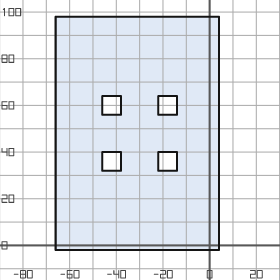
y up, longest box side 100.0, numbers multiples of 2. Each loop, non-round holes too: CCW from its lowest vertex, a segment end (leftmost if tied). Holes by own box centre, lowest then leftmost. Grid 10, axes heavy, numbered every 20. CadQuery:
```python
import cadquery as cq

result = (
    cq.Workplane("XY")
    .moveTo(-66.0, -2.0)
    .lineTo(4.0, -2.0)
    .lineTo(4.0, 98.0)
    .lineTo(-66.0, 98.0)
    .close()
    .moveTo(-46.0, 32.0)
    .lineTo(-38.0, 32.0)
    .lineTo(-38.0, 40.0)
    .lineTo(-46.0, 40.0)
    .close()
    .moveTo(-22.0, 32.0)
    .lineTo(-14.0, 32.0)
    .lineTo(-14.0, 40.0)
    .lineTo(-22.0, 40.0)
    .close()
    .moveTo(-46.0, 56.0)
    .lineTo(-38.0, 56.0)
    .lineTo(-38.0, 64.0)
    .lineTo(-46.0, 64.0)
    .close()
    .moveTo(-22.0, 56.0)
    .lineTo(-14.0, 56.0)
    .lineTo(-14.0, 64.0)
    .lineTo(-22.0, 64.0)
    .close()
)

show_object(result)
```